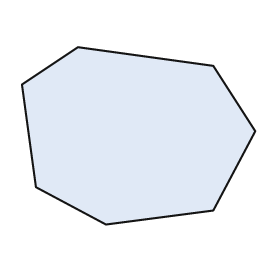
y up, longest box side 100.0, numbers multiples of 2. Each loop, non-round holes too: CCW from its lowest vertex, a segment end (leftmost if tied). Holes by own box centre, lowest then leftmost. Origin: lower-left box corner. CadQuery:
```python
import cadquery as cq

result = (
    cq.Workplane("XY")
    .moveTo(36.0, 0.0)
    .lineTo(82.0, 6.0)
    .lineTo(100.0, 40.0)
    .lineTo(82.0, 68.0)
    .lineTo(24.0, 76.0)
    .lineTo(0.0, 60.0)
    .lineTo(6.0, 16.0)
    .close()
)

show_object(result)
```